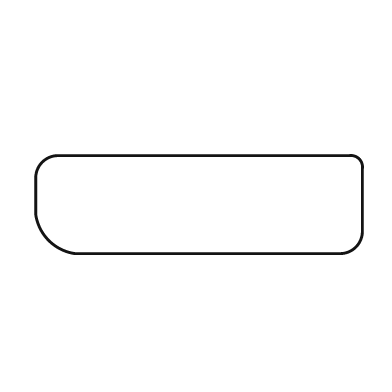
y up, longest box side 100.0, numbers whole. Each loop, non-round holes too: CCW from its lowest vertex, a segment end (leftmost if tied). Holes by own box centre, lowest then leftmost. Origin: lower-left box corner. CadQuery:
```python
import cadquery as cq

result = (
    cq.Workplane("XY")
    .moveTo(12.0, 0.0)
    .lineTo(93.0, 0.0)
    .threePointArc((98.0, 2.0), (100.0, 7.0))
    .lineTo(100.0, 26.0)
    .threePointArc((99.0, 29.0), (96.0, 30.0))
    .lineTo(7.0, 30.0)
    .threePointArc((2.0, 28.0), (0.0, 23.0))
    .lineTo(0.0, 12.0)
    .threePointArc((4.0, 4.0), (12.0, 0.0))
    .close()
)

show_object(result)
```